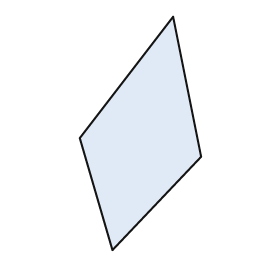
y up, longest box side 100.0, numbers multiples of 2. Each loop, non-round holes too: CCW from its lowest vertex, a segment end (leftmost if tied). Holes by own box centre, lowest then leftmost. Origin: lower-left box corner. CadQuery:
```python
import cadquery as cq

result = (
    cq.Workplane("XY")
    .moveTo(14.0, 0.0)
    .lineTo(52.0, 40.0)
    .lineTo(40.0, 100.0)
    .lineTo(0.0, 48.0)
    .close()
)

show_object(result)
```